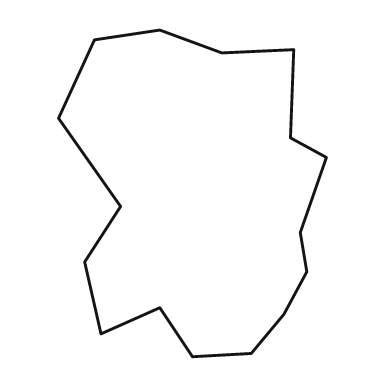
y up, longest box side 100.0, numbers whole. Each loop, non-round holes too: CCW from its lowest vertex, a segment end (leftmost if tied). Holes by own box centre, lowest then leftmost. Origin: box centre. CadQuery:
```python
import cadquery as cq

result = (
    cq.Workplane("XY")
    .moveTo(0.0, -50.0)
    .lineTo(18.0, -49.0)
    .lineTo(28.0, -37.0)
    .lineTo(35.0, -24.0)
    .lineTo(33.0, -12.0)
    .lineTo(41.0, 11.0)
    .lineTo(30.0, 17.0)
    .lineTo(31.0, 44.0)
    .lineTo(9.0, 43.0)
    .lineTo(-10.0, 50.0)
    .lineTo(-30.0, 47.0)
    .lineTo(-41.0, 23.0)
    .lineTo(-22.0, -4.0)
    .lineTo(-33.0, -21.0)
    .lineTo(-28.0, -43.0)
    .lineTo(-10.0, -35.0)
    .close()
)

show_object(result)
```